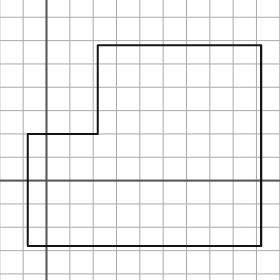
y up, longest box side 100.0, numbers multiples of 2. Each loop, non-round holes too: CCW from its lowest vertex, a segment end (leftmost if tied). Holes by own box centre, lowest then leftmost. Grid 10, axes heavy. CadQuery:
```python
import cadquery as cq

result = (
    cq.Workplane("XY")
    .moveTo(-8.0, -28.0)
    .lineTo(92.0, -28.0)
    .lineTo(92.0, 58.0)
    .lineTo(22.0, 58.0)
    .lineTo(22.0, 20.0)
    .lineTo(-8.0, 20.0)
    .close()
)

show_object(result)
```